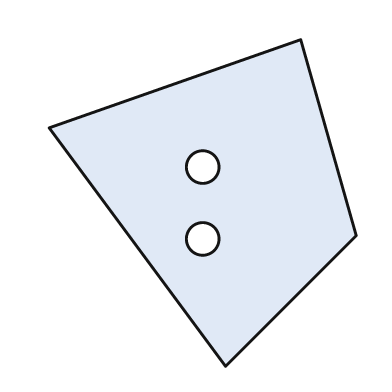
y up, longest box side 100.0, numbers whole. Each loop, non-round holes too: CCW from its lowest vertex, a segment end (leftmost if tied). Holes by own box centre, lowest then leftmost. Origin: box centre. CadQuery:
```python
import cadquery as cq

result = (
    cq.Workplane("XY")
    .moveTo(7.0, -50.0)
    .lineTo(47.0, -10.0)
    .lineTo(30.0, 50.0)
    .lineTo(-47.0, 23.0)
    .close()
    .moveTo(0.0, -11.0)
    .circle(5.0)
    .moveTo(0.0, 11.0)
    .circle(5.0)
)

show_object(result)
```